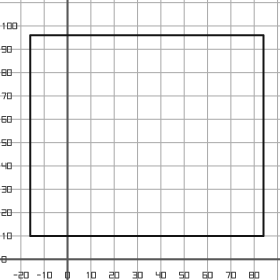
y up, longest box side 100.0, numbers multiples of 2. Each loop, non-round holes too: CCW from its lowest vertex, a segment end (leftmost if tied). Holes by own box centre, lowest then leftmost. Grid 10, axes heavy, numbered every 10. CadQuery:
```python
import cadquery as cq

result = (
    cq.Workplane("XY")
    .moveTo(-16.0, 10.0)
    .lineTo(84.0, 10.0)
    .lineTo(84.0, 96.0)
    .lineTo(-16.0, 96.0)
    .close()
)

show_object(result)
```